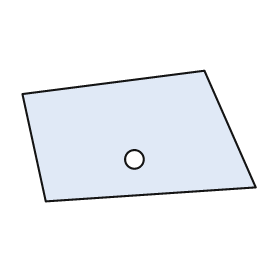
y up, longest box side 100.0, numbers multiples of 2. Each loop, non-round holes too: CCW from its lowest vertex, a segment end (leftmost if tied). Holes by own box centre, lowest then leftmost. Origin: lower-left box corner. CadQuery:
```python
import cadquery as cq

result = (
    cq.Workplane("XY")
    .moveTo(10.0, 0.0)
    .lineTo(100.0, 6.0)
    .lineTo(78.0, 56.0)
    .lineTo(0.0, 46.0)
    .close()
    .moveTo(48.0, 18.0)
    .circle(4.0)
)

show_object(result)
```